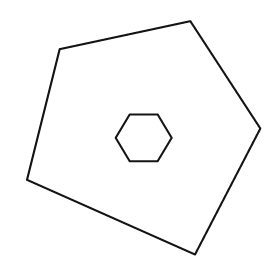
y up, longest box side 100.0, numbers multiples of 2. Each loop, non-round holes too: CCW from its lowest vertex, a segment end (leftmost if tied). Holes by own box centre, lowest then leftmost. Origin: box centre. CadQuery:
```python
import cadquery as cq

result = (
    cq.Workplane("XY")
    .moveTo(22.0, -50.0)
    .lineTo(50.0, 4.0)
    .lineTo(20.0, 50.0)
    .lineTo(-36.0, 38.0)
    .lineTo(-50.0, -18.0)
    .close()
    .moveTo(-6.0, -10.0)
    .lineTo(6.0, -10.0)
    .lineTo(12.0, 0.0)
    .lineTo(6.0, 10.0)
    .lineTo(-6.0, 10.0)
    .lineTo(-12.0, 0.0)
    .close()
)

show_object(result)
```